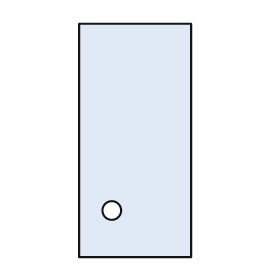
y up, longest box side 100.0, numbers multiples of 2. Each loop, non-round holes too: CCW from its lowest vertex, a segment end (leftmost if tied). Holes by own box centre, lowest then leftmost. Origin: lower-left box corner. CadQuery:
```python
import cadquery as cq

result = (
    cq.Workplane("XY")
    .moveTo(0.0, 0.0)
    .lineTo(48.0, 0.0)
    .lineTo(48.0, 100.0)
    .lineTo(0.0, 100.0)
    .close()
    .moveTo(14.0, 20.0)
    .circle(4.0)
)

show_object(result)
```